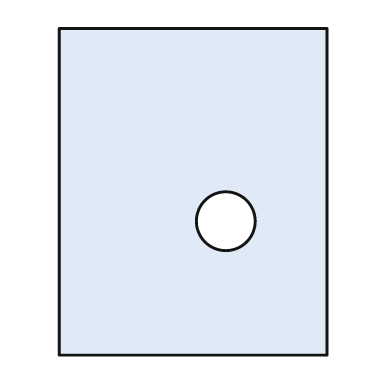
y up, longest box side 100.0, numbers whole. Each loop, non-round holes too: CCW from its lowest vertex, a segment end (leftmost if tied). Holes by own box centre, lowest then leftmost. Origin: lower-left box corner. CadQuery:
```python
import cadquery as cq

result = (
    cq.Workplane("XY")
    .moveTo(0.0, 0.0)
    .lineTo(82.0, 0.0)
    .lineTo(82.0, 100.0)
    .lineTo(0.0, 100.0)
    .close()
    .moveTo(51.0, 41.0)
    .circle(9.0)
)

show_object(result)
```